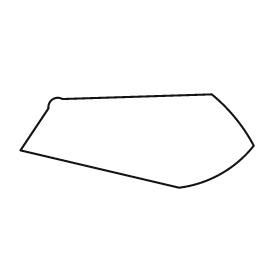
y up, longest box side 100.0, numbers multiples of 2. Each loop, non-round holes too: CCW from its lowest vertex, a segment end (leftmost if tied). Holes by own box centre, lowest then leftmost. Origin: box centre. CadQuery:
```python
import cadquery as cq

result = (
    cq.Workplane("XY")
    .moveTo(18.0, -20.0)
    .threePointArc((36.0, -14.0), (50.0, -2.0))
    .threePointArc((42.0, 10.0), (32.0, 20.0))
    .lineTo(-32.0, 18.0)
    .threePointArc((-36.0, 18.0), (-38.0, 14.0))
    .lineTo(-50.0, -4.0)
    .close()
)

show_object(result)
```